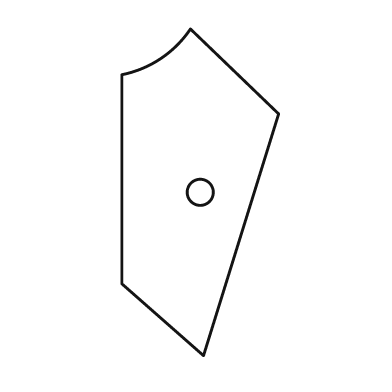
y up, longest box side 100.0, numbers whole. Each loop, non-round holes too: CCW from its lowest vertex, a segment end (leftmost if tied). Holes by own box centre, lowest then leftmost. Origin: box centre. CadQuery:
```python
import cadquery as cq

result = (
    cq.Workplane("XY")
    .moveTo(1.0, -50.0)
    .lineTo(24.0, 24.0)
    .lineTo(-3.0, 50.0)
    .threePointArc((-12.0, 41.0), (-24.0, 36.0))
    .lineTo(-24.0, -28.0)
    .close()
    .moveTo(0.0, 0.0)
    .circle(4.0)
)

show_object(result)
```